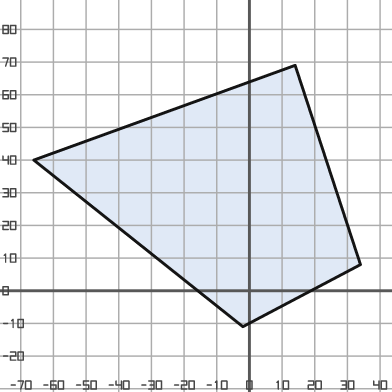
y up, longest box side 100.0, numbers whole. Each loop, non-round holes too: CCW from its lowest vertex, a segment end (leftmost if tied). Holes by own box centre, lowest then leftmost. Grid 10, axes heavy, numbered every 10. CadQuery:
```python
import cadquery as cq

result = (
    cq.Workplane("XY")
    .moveTo(-2.0, -11.0)
    .lineTo(34.0, 8.0)
    .lineTo(14.0, 69.0)
    .lineTo(-66.0, 40.0)
    .close()
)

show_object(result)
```